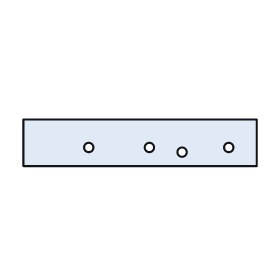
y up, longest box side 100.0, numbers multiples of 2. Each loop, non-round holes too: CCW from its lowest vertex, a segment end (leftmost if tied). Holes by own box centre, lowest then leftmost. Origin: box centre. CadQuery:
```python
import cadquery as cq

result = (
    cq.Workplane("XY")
    .moveTo(-50.0, -10.0)
    .lineTo(50.0, -10.0)
    .lineTo(50.0, 10.0)
    .lineTo(-50.0, 10.0)
    .close()
    .moveTo(18.0, -4.0)
    .circle(2.0)
    .moveTo(-22.0, -2.0)
    .circle(2.0)
    .moveTo(4.0, -2.0)
    .circle(2.0)
    .moveTo(38.0, -2.0)
    .circle(2.0)
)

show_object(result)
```